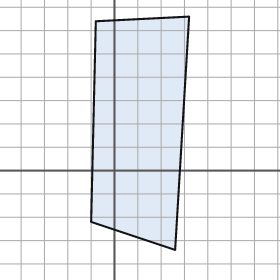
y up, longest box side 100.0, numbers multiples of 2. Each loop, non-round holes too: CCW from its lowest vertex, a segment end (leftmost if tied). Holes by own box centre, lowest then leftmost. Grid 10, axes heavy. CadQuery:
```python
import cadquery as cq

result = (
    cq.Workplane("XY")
    .moveTo(26.0, -34.0)
    .lineTo(32.0, 66.0)
    .lineTo(-8.0, 64.0)
    .lineTo(-10.0, -22.0)
    .close()
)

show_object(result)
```